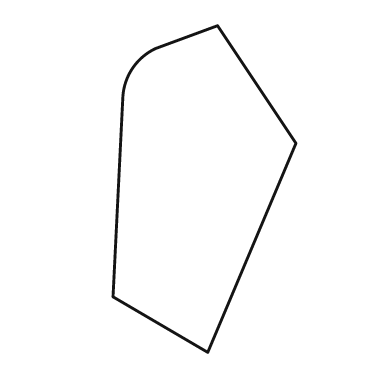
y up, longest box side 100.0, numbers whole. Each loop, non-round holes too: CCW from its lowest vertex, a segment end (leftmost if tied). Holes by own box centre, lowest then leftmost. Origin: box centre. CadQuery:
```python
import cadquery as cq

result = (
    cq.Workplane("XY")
    .moveTo(1.0, -50.0)
    .lineTo(28.0, 14.0)
    .lineTo(4.0, 50.0)
    .lineTo(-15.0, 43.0)
    .threePointArc((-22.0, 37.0), (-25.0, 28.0))
    .lineTo(-28.0, -33.0)
    .close()
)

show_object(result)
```